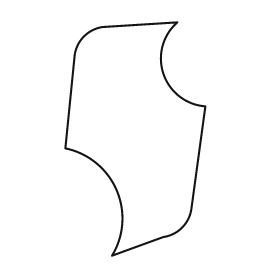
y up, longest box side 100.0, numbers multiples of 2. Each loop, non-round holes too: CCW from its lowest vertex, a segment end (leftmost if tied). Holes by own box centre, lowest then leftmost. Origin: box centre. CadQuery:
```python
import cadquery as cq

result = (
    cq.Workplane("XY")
    .moveTo(-10.0, -50.0)
    .lineTo(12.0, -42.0)
    .threePointArc((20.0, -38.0), (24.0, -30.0))
    .lineTo(30.0, 14.0)
    .threePointArc((12.0, 28.0), (18.0, 50.0))
    .lineTo(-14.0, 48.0)
    .threePointArc((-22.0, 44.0), (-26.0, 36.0))
    .lineTo(-30.0, -4.0)
    .threePointArc((-8.0, -22.0), (-10.0, -50.0))
    .close()
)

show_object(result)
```